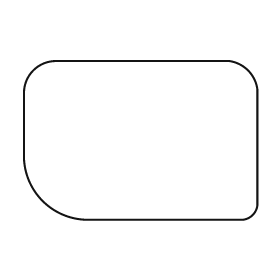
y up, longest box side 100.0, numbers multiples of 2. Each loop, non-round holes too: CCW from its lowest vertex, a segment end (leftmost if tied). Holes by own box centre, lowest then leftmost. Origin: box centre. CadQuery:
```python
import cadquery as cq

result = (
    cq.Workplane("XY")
    .moveTo(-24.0, -34.0)
    .lineTo(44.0, -34.0)
    .threePointArc((48.0, -32.0), (50.0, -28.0))
    .lineTo(50.0, 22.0)
    .threePointArc((46.0, 30.0), (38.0, 34.0))
    .lineTo(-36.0, 34.0)
    .threePointArc((-46.0, 30.0), (-50.0, 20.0))
    .lineTo(-50.0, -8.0)
    .threePointArc((-42.0, -26.0), (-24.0, -34.0))
    .close()
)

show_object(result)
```